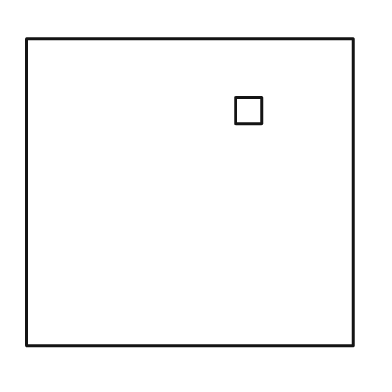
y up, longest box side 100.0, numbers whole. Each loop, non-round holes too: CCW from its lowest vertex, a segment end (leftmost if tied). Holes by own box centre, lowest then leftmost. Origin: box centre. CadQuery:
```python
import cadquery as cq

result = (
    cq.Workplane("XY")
    .moveTo(-50.0, -47.0)
    .lineTo(50.0, -47.0)
    .lineTo(50.0, 47.0)
    .lineTo(-50.0, 47.0)
    .close()
    .moveTo(14.0, 21.0)
    .lineTo(22.0, 21.0)
    .lineTo(22.0, 29.0)
    .lineTo(14.0, 29.0)
    .close()
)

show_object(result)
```